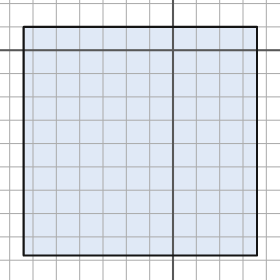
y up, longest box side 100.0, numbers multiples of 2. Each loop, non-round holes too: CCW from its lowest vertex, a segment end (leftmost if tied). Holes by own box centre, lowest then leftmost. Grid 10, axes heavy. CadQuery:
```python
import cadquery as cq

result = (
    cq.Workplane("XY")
    .moveTo(-64.0, -88.0)
    .lineTo(36.0, -88.0)
    .lineTo(36.0, 10.0)
    .lineTo(-64.0, 10.0)
    .close()
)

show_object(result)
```